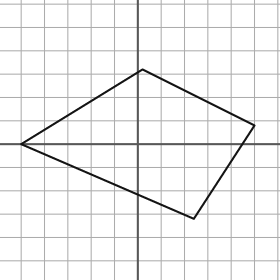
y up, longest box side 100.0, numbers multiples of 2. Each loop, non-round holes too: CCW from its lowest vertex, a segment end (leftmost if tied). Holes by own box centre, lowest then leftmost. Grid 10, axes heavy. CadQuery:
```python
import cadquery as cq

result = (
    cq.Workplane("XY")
    .moveTo(24.0, -32.0)
    .lineTo(50.0, 8.0)
    .lineTo(2.0, 32.0)
    .lineTo(-50.0, 0.0)
    .close()
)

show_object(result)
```